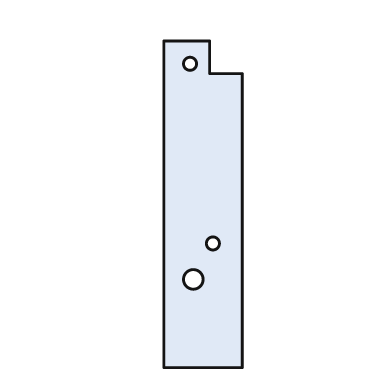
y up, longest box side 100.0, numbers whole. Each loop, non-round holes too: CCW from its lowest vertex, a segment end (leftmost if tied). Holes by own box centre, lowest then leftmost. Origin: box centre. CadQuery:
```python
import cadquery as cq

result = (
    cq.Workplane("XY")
    .moveTo(-12.0, -50.0)
    .lineTo(12.0, -50.0)
    .lineTo(12.0, 40.0)
    .lineTo(2.0, 40.0)
    .lineTo(2.0, 50.0)
    .lineTo(-12.0, 50.0)
    .close()
    .moveTo(-3.0, -23.0)
    .circle(3.0)
    .moveTo(3.0, -12.0)
    .circle(2.0)
    .moveTo(-4.0, 43.0)
    .circle(2.0)
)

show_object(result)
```